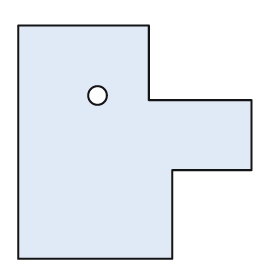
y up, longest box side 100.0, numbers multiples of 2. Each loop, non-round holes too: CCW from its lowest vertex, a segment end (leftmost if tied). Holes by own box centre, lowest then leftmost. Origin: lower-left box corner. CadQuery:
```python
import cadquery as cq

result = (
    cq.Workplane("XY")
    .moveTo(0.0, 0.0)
    .lineTo(66.0, 0.0)
    .lineTo(66.0, 38.0)
    .lineTo(100.0, 38.0)
    .lineTo(100.0, 68.0)
    .lineTo(56.0, 68.0)
    .lineTo(56.0, 100.0)
    .lineTo(0.0, 100.0)
    .close()
    .moveTo(34.0, 70.0)
    .circle(4.0)
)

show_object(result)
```